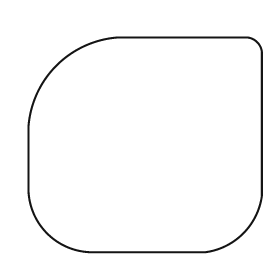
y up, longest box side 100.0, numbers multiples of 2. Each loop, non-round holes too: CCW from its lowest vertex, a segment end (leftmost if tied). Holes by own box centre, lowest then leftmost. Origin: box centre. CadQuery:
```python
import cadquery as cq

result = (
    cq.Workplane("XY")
    .moveTo(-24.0, -46.0)
    .lineTo(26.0, -46.0)
    .threePointArc((42.0, -38.0), (50.0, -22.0))
    .lineTo(50.0, 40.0)
    .threePointArc((48.0, 44.0), (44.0, 46.0))
    .lineTo(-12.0, 46.0)
    .threePointArc((-38.0, 34.0), (-50.0, 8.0))
    .lineTo(-50.0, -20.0)
    .threePointArc((-42.0, -38.0), (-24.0, -46.0))
    .close()
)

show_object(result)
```